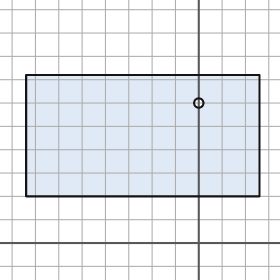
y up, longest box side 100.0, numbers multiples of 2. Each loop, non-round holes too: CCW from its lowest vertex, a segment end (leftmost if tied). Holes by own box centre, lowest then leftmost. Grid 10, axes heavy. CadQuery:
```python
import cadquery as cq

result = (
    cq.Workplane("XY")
    .moveTo(-74.0, 20.0)
    .lineTo(26.0, 20.0)
    .lineTo(26.0, 72.0)
    .lineTo(-74.0, 72.0)
    .close()
    .moveTo(0.0, 60.0)
    .circle(2.0)
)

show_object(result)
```